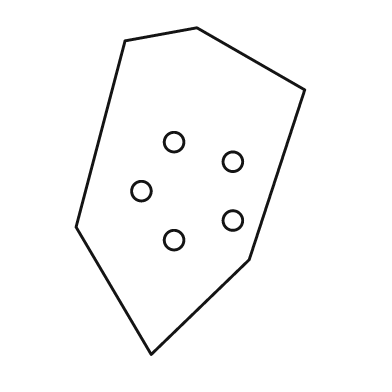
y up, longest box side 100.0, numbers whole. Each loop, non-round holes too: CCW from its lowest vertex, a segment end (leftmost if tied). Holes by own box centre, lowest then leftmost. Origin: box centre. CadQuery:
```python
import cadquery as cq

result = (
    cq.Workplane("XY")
    .moveTo(-12.0, -50.0)
    .lineTo(18.0, -21.0)
    .lineTo(35.0, 31.0)
    .lineTo(2.0, 50.0)
    .lineTo(-20.0, 46.0)
    .lineTo(-35.0, -11.0)
    .close()
    .moveTo(-5.0, -15.0)
    .circle(3.0)
    .moveTo(13.0, -9.0)
    .circle(3.0)
    .moveTo(-15.0, 0.0)
    .circle(3.0)
    .moveTo(13.0, 9.0)
    .circle(3.0)
    .moveTo(-5.0, 15.0)
    .circle(3.0)
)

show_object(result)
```